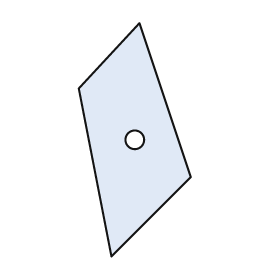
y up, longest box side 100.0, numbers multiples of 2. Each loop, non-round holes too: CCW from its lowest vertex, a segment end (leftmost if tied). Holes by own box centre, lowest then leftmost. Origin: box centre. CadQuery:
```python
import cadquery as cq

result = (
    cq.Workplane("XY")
    .moveTo(-10.0, -50.0)
    .lineTo(24.0, -16.0)
    .lineTo(2.0, 50.0)
    .lineTo(-24.0, 22.0)
    .close()
    .moveTo(0.0, 0.0)
    .circle(4.0)
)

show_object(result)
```